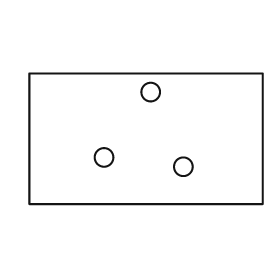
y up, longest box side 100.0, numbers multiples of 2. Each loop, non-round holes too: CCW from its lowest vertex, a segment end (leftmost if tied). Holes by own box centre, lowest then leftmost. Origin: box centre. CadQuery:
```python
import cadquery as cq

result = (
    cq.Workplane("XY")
    .moveTo(-50.0, -28.0)
    .lineTo(50.0, -28.0)
    .lineTo(50.0, 28.0)
    .lineTo(-50.0, 28.0)
    .close()
    .moveTo(16.0, -12.0)
    .circle(4.0)
    .moveTo(-18.0, -8.0)
    .circle(4.0)
    .moveTo(2.0, 20.0)
    .circle(4.0)
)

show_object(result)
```